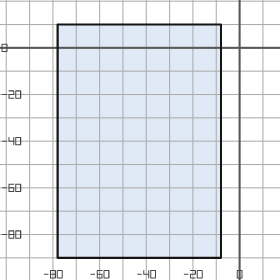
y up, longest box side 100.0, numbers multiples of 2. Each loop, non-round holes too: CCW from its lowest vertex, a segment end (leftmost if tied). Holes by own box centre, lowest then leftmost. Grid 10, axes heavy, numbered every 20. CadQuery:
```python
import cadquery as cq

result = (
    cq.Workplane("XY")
    .moveTo(-78.0, -90.0)
    .lineTo(-8.0, -90.0)
    .lineTo(-8.0, 10.0)
    .lineTo(-78.0, 10.0)
    .close()
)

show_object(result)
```